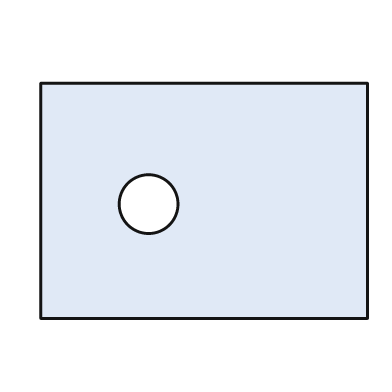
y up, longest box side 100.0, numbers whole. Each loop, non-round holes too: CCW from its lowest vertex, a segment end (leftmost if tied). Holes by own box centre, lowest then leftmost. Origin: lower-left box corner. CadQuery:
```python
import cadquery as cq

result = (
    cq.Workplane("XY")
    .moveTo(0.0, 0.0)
    .lineTo(100.0, 0.0)
    .lineTo(100.0, 72.0)
    .lineTo(0.0, 72.0)
    .close()
    .moveTo(33.0, 35.0)
    .circle(9.0)
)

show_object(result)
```